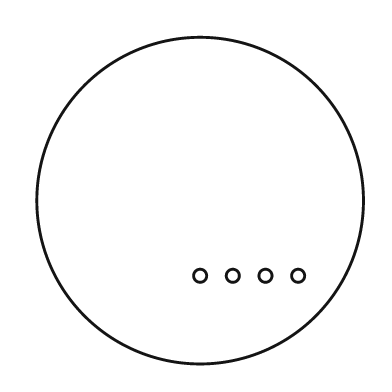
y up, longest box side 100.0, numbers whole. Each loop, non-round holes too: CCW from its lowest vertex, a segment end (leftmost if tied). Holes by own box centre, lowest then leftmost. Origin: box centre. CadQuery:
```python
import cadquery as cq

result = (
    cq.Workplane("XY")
    .moveTo(0.0, 0.0)
    .circle(50.0)
    .moveTo(0.0, -23.0)
    .circle(2.0)
    .moveTo(10.0, -23.0)
    .circle(2.0)
    .moveTo(20.0, -23.0)
    .circle(2.0)
    .moveTo(30.0, -23.0)
    .circle(2.0)
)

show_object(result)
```